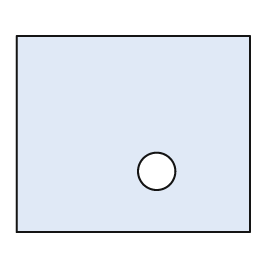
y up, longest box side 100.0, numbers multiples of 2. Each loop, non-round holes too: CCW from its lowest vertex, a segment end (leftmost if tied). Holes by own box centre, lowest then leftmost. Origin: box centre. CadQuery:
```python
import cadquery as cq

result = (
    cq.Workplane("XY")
    .moveTo(-50.0, -42.0)
    .lineTo(50.0, -42.0)
    .lineTo(50.0, 42.0)
    .lineTo(-50.0, 42.0)
    .close()
    .moveTo(10.0, -16.0)
    .circle(8.0)
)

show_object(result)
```